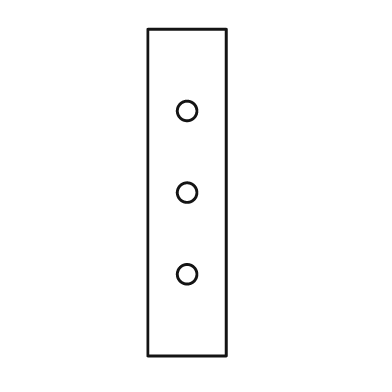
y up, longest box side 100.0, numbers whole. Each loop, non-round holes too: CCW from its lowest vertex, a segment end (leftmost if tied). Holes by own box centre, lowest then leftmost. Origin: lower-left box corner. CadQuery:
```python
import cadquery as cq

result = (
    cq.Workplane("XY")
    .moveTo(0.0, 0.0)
    .lineTo(24.0, 0.0)
    .lineTo(24.0, 100.0)
    .lineTo(0.0, 100.0)
    .close()
    .moveTo(12.0, 25.0)
    .circle(3.0)
    .moveTo(12.0, 50.0)
    .circle(3.0)
    .moveTo(12.0, 75.0)
    .circle(3.0)
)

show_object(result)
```